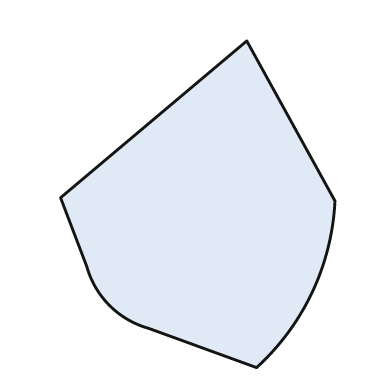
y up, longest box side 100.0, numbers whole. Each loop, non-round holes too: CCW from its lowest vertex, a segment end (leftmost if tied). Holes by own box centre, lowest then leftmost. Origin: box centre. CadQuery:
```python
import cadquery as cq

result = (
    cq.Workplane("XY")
    .moveTo(18.0, -50.0)
    .threePointArc((35.0, -27.0), (42.0, 1.0))
    .lineTo(15.0, 50.0)
    .lineTo(-42.0, 2.0)
    .lineTo(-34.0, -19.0)
    .threePointArc((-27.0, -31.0), (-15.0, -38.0))
    .close()
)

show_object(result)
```